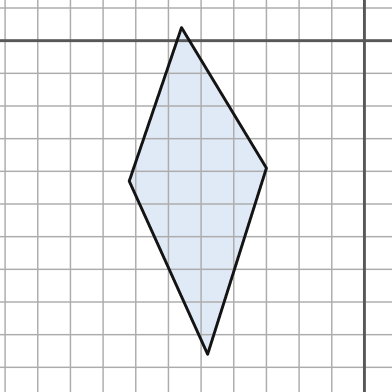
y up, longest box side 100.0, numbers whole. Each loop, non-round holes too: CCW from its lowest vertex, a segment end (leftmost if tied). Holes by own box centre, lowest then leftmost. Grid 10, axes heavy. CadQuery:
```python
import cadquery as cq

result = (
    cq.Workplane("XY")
    .moveTo(-48.0, -96.0)
    .lineTo(-30.0, -39.0)
    .lineTo(-56.0, 4.0)
    .lineTo(-72.0, -43.0)
    .close()
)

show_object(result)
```